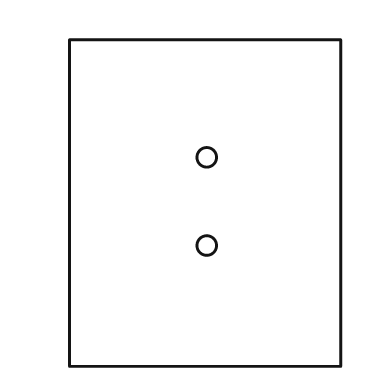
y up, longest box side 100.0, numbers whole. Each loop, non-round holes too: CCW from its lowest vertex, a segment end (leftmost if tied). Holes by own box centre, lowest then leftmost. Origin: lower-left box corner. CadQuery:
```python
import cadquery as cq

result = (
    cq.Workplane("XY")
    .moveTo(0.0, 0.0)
    .lineTo(83.0, 0.0)
    .lineTo(83.0, 100.0)
    .lineTo(0.0, 100.0)
    .close()
    .moveTo(42.0, 37.0)
    .circle(3.0)
    .moveTo(42.0, 64.0)
    .circle(3.0)
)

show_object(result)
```